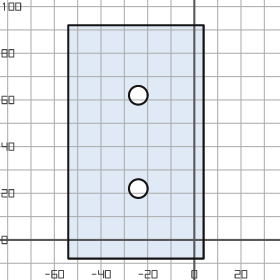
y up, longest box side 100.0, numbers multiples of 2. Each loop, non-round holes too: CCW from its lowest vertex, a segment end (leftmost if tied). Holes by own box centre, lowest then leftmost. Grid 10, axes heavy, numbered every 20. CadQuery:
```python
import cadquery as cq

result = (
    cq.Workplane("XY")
    .moveTo(-54.0, -8.0)
    .lineTo(4.0, -8.0)
    .lineTo(4.0, 92.0)
    .lineTo(-54.0, 92.0)
    .close()
    .moveTo(-24.0, 22.0)
    .circle(4.0)
    .moveTo(-24.0, 62.0)
    .circle(4.0)
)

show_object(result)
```